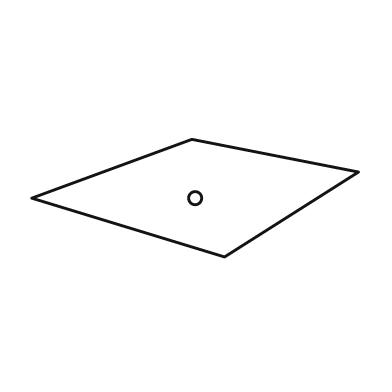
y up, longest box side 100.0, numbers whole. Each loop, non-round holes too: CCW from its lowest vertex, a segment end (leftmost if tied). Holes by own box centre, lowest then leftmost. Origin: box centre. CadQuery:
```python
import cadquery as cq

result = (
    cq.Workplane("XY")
    .moveTo(9.0, -18.0)
    .lineTo(50.0, 8.0)
    .lineTo(-1.0, 18.0)
    .lineTo(-50.0, 0.0)
    .close()
    .moveTo(0.0, 0.0)
    .circle(2.0)
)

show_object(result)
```